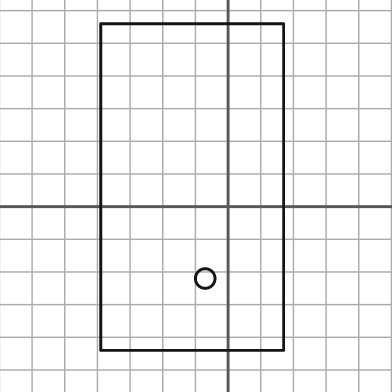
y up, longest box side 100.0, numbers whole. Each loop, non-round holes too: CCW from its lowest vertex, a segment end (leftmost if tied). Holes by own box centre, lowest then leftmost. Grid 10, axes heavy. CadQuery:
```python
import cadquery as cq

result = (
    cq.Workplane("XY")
    .moveTo(-39.0, -44.0)
    .lineTo(17.0, -44.0)
    .lineTo(17.0, 56.0)
    .lineTo(-39.0, 56.0)
    .close()
    .moveTo(-7.0, -22.0)
    .circle(3.0)
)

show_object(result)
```